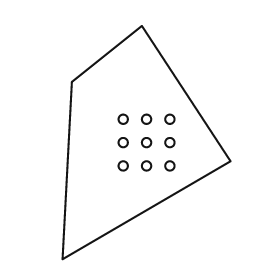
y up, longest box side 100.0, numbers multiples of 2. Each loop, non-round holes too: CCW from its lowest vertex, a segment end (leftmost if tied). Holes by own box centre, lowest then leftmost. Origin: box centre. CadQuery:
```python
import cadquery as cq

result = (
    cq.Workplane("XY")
    .moveTo(-36.0, -50.0)
    .lineTo(36.0, -8.0)
    .lineTo(-2.0, 50.0)
    .lineTo(-32.0, 26.0)
    .close()
    .moveTo(-10.0, -10.0)
    .circle(2.0)
    .moveTo(0.0, -10.0)
    .circle(2.0)
    .moveTo(10.0, -10.0)
    .circle(2.0)
    .moveTo(-10.0, 0.0)
    .circle(2.0)
    .moveTo(0.0, 0.0)
    .circle(2.0)
    .moveTo(10.0, 0.0)
    .circle(2.0)
    .moveTo(-10.0, 10.0)
    .circle(2.0)
    .moveTo(0.0, 10.0)
    .circle(2.0)
    .moveTo(10.0, 10.0)
    .circle(2.0)
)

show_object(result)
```